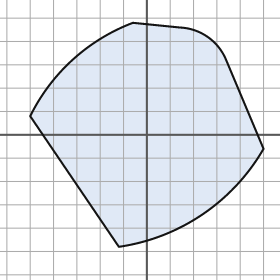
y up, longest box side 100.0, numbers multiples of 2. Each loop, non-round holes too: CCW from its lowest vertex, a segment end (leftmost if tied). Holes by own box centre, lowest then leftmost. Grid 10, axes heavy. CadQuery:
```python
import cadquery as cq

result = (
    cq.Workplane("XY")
    .moveTo(-12.0, -48.0)
    .threePointArc((24.0, -34.0), (50.0, -6.0))
    .lineTo(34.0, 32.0)
    .threePointArc((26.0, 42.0), (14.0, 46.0))
    .lineTo(-6.0, 48.0)
    .threePointArc((-32.0, 32.0), (-50.0, 8.0))
    .close()
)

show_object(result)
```